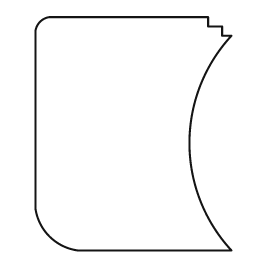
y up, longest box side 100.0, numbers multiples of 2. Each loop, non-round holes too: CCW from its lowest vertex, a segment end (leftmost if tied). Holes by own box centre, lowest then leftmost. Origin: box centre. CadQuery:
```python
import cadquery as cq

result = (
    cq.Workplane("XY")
    .moveTo(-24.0, -50.0)
    .lineTo(42.0, -50.0)
    .threePointArc((24.0, -4.0), (42.0, 42.0))
    .lineTo(38.0, 42.0)
    .lineTo(38.0, 46.0)
    .lineTo(32.0, 46.0)
    .lineTo(32.0, 50.0)
    .lineTo(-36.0, 50.0)
    .threePointArc((-40.0, 48.0), (-42.0, 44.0))
    .lineTo(-42.0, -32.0)
    .threePointArc((-36.0, -44.0), (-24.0, -50.0))
    .close()
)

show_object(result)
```